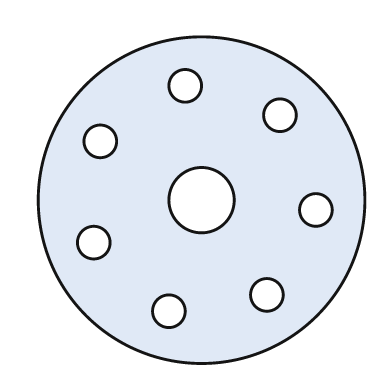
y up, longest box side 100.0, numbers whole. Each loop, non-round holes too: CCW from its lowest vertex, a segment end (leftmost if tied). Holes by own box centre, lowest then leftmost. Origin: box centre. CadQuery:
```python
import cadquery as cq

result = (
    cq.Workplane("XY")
    .moveTo(0.0, 0.0)
    .circle(50.0)
    .moveTo(-10.0, -34.0)
    .circle(5.0)
    .moveTo(20.0, -29.0)
    .circle(5.0)
    .moveTo(-33.0, -13.0)
    .circle(5.0)
    .moveTo(35.0, -3.0)
    .circle(5.0)
    .moveTo(0.0, 0.0)
    .circle(10.0)
    .moveTo(-31.0, 18.0)
    .circle(5.0)
    .moveTo(24.0, 26.0)
    .circle(5.0)
    .moveTo(-5.0, 35.0)
    .circle(5.0)
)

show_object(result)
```